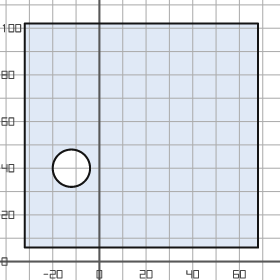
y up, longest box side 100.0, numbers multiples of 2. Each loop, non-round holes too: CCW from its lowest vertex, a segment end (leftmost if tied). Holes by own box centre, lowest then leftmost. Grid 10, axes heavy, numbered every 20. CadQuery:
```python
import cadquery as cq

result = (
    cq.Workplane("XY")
    .moveTo(-32.0, 6.0)
    .lineTo(68.0, 6.0)
    .lineTo(68.0, 102.0)
    .lineTo(-32.0, 102.0)
    .close()
    .moveTo(-12.0, 40.0)
    .circle(8.0)
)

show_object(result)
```